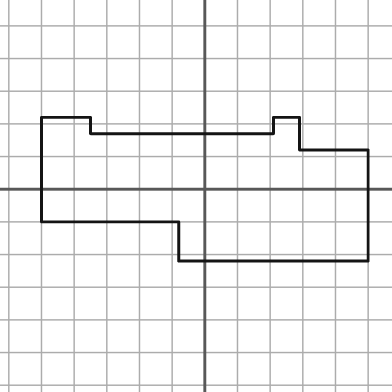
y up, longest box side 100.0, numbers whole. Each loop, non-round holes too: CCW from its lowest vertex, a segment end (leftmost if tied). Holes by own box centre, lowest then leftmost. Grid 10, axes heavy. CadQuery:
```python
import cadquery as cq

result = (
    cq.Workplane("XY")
    .moveTo(-8.0, -22.0)
    .lineTo(50.0, -22.0)
    .lineTo(50.0, 12.0)
    .lineTo(29.0, 12.0)
    .lineTo(29.0, 22.0)
    .lineTo(21.0, 22.0)
    .lineTo(21.0, 17.0)
    .lineTo(-35.0, 17.0)
    .lineTo(-35.0, 22.0)
    .lineTo(-50.0, 22.0)
    .lineTo(-50.0, -10.0)
    .lineTo(-8.0, -10.0)
    .close()
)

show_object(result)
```